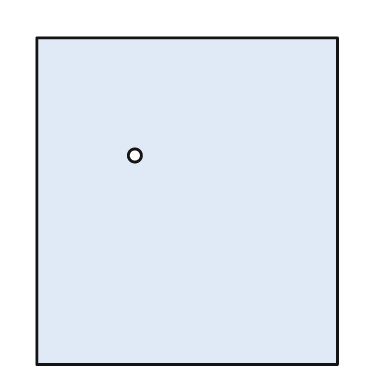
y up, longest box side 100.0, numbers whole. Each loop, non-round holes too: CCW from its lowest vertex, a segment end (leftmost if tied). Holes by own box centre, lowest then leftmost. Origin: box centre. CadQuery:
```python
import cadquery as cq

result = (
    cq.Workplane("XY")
    .moveTo(-46.0, -50.0)
    .lineTo(46.0, -50.0)
    .lineTo(46.0, 50.0)
    .lineTo(-46.0, 50.0)
    .close()
    .moveTo(-16.0, 14.0)
    .circle(2.0)
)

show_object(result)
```